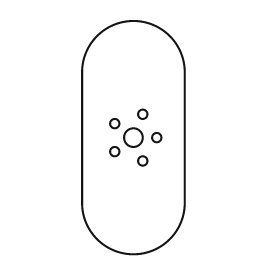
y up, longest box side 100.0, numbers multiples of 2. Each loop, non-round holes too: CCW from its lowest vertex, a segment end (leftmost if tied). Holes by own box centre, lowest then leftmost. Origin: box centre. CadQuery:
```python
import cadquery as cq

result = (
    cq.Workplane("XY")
    .moveTo(-22.0, -28.0)
    .threePointArc((0.0, -50.0), (22.0, -28.0))
    .lineTo(22.0, 28.0)
    .threePointArc((0.0, 50.0), (-22.0, 28.0))
    .close()
    .moveTo(4.0, -10.0)
    .circle(2.0)
    .moveTo(-8.0, -6.0)
    .circle(2.0)
    .moveTo(0.0, 0.0)
    .circle(4.0)
    .moveTo(10.0, 0.0)
    .circle(2.0)
    .moveTo(-8.0, 6.0)
    .circle(2.0)
    .moveTo(4.0, 10.0)
    .circle(2.0)
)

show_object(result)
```